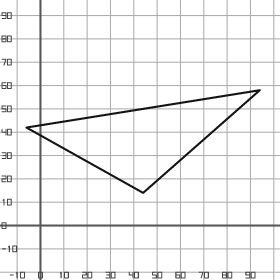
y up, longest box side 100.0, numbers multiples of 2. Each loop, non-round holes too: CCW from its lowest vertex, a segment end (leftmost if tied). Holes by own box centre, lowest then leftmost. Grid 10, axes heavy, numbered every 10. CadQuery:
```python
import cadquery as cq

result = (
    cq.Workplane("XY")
    .moveTo(44.0, 14.0)
    .lineTo(94.0, 58.0)
    .lineTo(-6.0, 42.0)
    .close()
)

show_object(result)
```